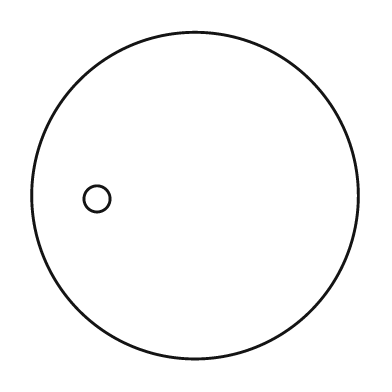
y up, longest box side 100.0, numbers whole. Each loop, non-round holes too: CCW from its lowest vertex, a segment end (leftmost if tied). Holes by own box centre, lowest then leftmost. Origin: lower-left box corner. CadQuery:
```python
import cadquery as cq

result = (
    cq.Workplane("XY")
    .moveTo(50.0, 50.0)
    .circle(50.0)
    .moveTo(20.0, 49.0)
    .circle(4.0)
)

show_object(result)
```